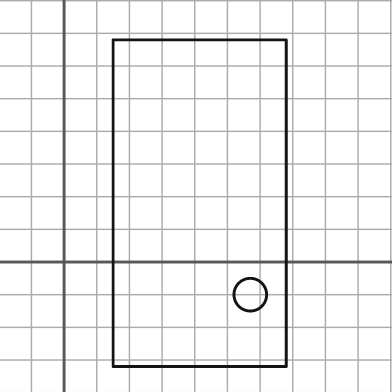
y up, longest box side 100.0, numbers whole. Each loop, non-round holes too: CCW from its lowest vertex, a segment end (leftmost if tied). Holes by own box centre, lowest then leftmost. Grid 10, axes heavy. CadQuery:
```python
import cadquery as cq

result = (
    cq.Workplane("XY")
    .moveTo(15.0, -32.0)
    .lineTo(68.0, -32.0)
    .lineTo(68.0, 68.0)
    .lineTo(15.0, 68.0)
    .close()
    .moveTo(57.0, -10.0)
    .circle(5.0)
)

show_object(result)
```